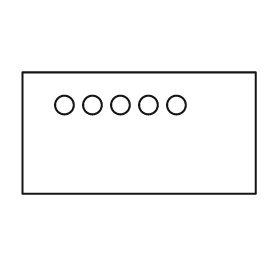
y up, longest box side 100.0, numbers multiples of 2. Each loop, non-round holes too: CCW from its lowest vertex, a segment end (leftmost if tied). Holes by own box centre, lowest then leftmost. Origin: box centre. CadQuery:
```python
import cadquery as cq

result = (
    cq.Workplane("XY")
    .moveTo(-50.0, -26.0)
    .lineTo(50.0, -26.0)
    .lineTo(50.0, 26.0)
    .lineTo(-50.0, 26.0)
    .close()
    .moveTo(-32.0, 12.0)
    .circle(4.0)
    .moveTo(-20.0, 12.0)
    .circle(4.0)
    .moveTo(-8.0, 12.0)
    .circle(4.0)
    .moveTo(4.0, 12.0)
    .circle(4.0)
    .moveTo(16.0, 12.0)
    .circle(4.0)
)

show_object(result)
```